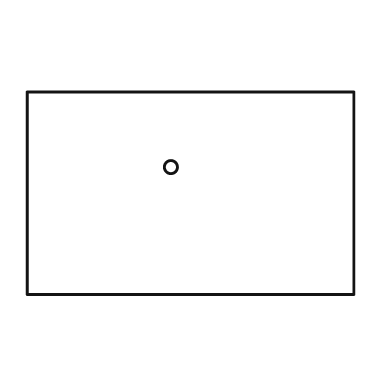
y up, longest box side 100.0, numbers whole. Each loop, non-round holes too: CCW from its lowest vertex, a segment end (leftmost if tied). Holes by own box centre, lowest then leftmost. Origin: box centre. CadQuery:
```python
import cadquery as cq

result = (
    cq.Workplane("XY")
    .moveTo(-50.0, -31.0)
    .lineTo(50.0, -31.0)
    .lineTo(50.0, 31.0)
    .lineTo(-50.0, 31.0)
    .close()
    .moveTo(-6.0, 8.0)
    .circle(2.0)
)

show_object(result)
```